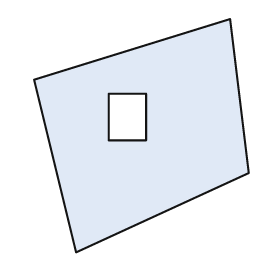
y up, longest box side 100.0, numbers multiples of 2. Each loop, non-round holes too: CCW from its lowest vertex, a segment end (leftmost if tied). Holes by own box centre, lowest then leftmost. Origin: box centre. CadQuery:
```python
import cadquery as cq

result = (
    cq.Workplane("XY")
    .moveTo(-28.0, -50.0)
    .lineTo(46.0, -16.0)
    .lineTo(38.0, 50.0)
    .lineTo(-46.0, 24.0)
    .close()
    .moveTo(-14.0, -2.0)
    .lineTo(2.0, -2.0)
    .lineTo(2.0, 18.0)
    .lineTo(-14.0, 18.0)
    .close()
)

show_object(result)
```